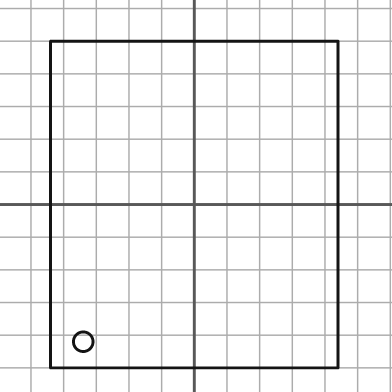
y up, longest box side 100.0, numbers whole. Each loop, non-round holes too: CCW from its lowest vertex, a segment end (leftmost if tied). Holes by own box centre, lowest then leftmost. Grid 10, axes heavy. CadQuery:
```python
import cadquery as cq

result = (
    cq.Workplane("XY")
    .moveTo(-44.0, -50.0)
    .lineTo(44.0, -50.0)
    .lineTo(44.0, 50.0)
    .lineTo(-44.0, 50.0)
    .close()
    .moveTo(-34.0, -42.0)
    .circle(3.0)
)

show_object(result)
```